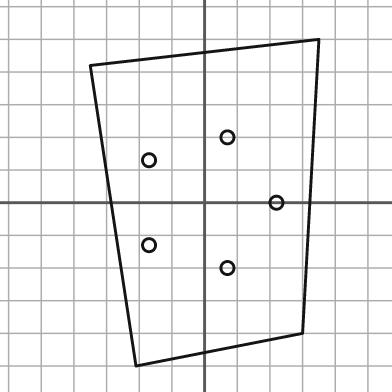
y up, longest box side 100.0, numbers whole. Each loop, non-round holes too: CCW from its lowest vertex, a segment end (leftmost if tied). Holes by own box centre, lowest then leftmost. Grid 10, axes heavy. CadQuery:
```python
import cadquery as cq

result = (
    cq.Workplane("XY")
    .moveTo(-21.0, -50.0)
    .lineTo(30.0, -40.0)
    .lineTo(35.0, 50.0)
    .lineTo(-35.0, 42.0)
    .close()
    .moveTo(7.0, -20.0)
    .circle(2.0)
    .moveTo(-17.0, -13.0)
    .circle(2.0)
    .moveTo(22.0, 0.0)
    .circle(2.0)
    .moveTo(-17.0, 13.0)
    .circle(2.0)
    .moveTo(7.0, 20.0)
    .circle(2.0)
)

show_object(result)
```